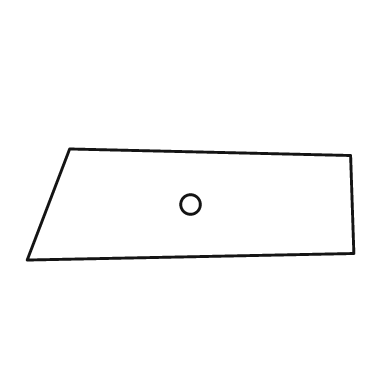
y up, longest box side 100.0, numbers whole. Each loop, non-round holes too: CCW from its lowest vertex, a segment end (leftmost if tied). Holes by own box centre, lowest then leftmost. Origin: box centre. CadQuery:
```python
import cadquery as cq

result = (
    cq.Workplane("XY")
    .moveTo(-50.0, -17.0)
    .lineTo(50.0, -15.0)
    .lineTo(49.0, 15.0)
    .lineTo(-37.0, 17.0)
    .close()
    .moveTo(0.0, 0.0)
    .circle(3.0)
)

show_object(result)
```